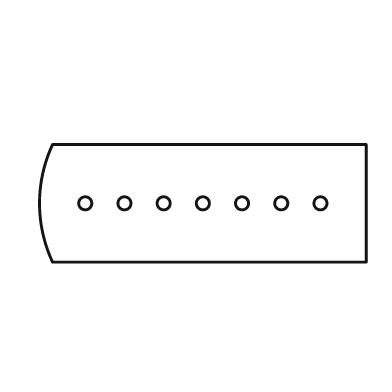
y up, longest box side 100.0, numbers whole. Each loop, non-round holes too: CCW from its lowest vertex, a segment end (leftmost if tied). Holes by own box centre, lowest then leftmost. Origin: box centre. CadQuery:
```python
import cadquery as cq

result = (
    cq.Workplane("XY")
    .moveTo(-46.0, -18.0)
    .lineTo(50.0, -18.0)
    .lineTo(50.0, 18.0)
    .lineTo(-46.0, 18.0)
    .threePointArc((-50.0, 0.0), (-46.0, -18.0))
    .close()
    .moveTo(-36.0, 0.0)
    .circle(2.0)
    .moveTo(-24.0, 0.0)
    .circle(2.0)
    .moveTo(-12.0, 0.0)
    .circle(2.0)
    .moveTo(0.0, 0.0)
    .circle(2.0)
    .moveTo(12.0, 0.0)
    .circle(2.0)
    .moveTo(24.0, 0.0)
    .circle(2.0)
    .moveTo(36.0, 0.0)
    .circle(2.0)
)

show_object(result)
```